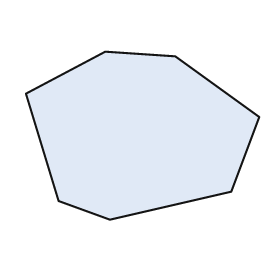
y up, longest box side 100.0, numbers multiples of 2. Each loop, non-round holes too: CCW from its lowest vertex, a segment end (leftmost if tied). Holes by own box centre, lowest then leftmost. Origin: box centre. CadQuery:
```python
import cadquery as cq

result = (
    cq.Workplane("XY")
    .moveTo(-14.0, -36.0)
    .lineTo(38.0, -24.0)
    .lineTo(50.0, 8.0)
    .lineTo(14.0, 34.0)
    .lineTo(-16.0, 36.0)
    .lineTo(-50.0, 18.0)
    .lineTo(-36.0, -28.0)
    .close()
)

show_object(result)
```